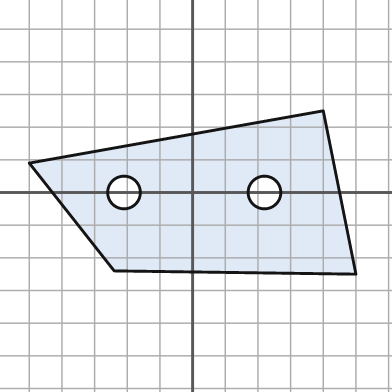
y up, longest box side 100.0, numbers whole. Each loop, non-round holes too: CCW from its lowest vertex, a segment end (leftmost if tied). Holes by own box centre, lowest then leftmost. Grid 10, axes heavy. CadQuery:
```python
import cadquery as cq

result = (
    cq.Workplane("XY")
    .moveTo(50.0, -25.0)
    .lineTo(40.0, 25.0)
    .lineTo(-50.0, 9.0)
    .lineTo(-24.0, -24.0)
    .close()
    .moveTo(-21.0, 0.0)
    .circle(5.0)
    .moveTo(22.0, 0.0)
    .circle(5.0)
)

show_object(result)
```